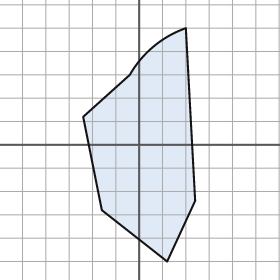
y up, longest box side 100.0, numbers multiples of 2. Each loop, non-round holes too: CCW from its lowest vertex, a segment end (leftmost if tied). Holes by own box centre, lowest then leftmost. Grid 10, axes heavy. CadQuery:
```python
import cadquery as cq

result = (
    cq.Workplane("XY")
    .moveTo(12.0, -50.0)
    .lineTo(24.0, -24.0)
    .lineTo(20.0, 50.0)
    .threePointArc((6.0, 42.0), (-4.0, 30.0))
    .lineTo(-24.0, 12.0)
    .lineTo(-16.0, -28.0)
    .close()
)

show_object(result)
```